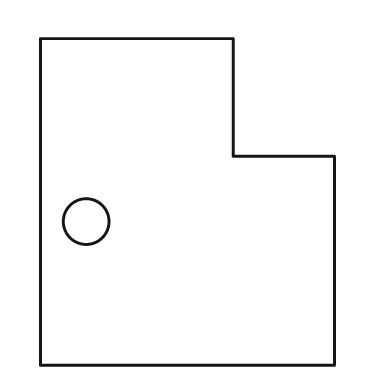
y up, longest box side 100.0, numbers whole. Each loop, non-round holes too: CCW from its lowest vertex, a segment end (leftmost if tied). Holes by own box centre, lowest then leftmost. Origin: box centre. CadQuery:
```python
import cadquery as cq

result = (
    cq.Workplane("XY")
    .moveTo(-45.0, -50.0)
    .lineTo(45.0, -50.0)
    .lineTo(45.0, 14.0)
    .lineTo(14.0, 14.0)
    .lineTo(14.0, 50.0)
    .lineTo(-45.0, 50.0)
    .close()
    .moveTo(-31.0, -6.0)
    .circle(7.0)
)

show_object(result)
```